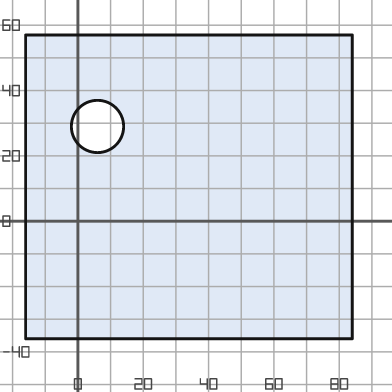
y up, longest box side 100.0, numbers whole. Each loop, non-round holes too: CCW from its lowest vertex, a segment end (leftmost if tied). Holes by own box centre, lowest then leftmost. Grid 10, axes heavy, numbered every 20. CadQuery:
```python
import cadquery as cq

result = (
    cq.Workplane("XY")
    .moveTo(-16.0, -36.0)
    .lineTo(84.0, -36.0)
    .lineTo(84.0, 57.0)
    .lineTo(-16.0, 57.0)
    .close()
    .moveTo(6.0, 29.0)
    .circle(8.0)
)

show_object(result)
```